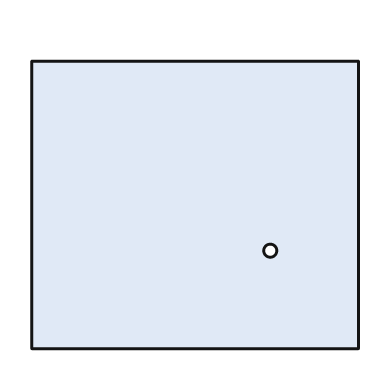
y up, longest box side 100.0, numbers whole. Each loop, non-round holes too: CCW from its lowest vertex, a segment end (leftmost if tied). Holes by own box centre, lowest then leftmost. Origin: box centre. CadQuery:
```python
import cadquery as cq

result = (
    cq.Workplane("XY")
    .moveTo(-50.0, -44.0)
    .lineTo(50.0, -44.0)
    .lineTo(50.0, 44.0)
    .lineTo(-50.0, 44.0)
    .close()
    .moveTo(23.0, -14.0)
    .circle(2.0)
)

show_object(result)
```